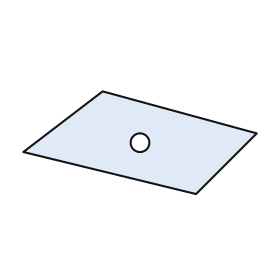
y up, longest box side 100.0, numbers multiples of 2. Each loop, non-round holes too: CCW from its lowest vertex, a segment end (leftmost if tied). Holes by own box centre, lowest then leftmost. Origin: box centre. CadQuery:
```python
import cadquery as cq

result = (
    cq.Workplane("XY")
    .moveTo(24.0, -22.0)
    .lineTo(50.0, 4.0)
    .lineTo(-16.0, 22.0)
    .lineTo(-50.0, -4.0)
    .close()
    .moveTo(0.0, 0.0)
    .circle(4.0)
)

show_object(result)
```